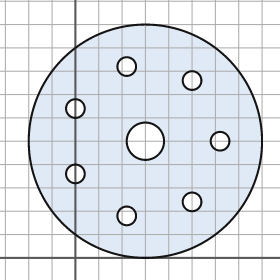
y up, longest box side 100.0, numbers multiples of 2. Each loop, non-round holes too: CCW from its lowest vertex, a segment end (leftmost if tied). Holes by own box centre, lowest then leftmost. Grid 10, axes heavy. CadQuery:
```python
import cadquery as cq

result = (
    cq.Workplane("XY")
    .moveTo(30.0, 50.0)
    .circle(50.0)
    .moveTo(22.0, 18.0)
    .circle(4.0)
    .moveTo(50.0, 24.0)
    .circle(4.0)
    .moveTo(0.0, 36.0)
    .circle(4.0)
    .moveTo(30.0, 50.0)
    .circle(8.0)
    .moveTo(62.0, 50.0)
    .circle(4.0)
    .moveTo(0.0, 64.0)
    .circle(4.0)
    .moveTo(50.0, 76.0)
    .circle(4.0)
    .moveTo(22.0, 82.0)
    .circle(4.0)
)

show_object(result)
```